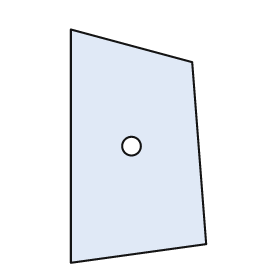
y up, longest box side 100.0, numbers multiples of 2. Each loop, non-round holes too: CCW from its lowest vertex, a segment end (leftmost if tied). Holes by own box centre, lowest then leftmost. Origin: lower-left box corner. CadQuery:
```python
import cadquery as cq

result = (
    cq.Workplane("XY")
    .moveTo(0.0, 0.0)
    .lineTo(58.0, 8.0)
    .lineTo(52.0, 86.0)
    .lineTo(0.0, 100.0)
    .close()
    .moveTo(26.0, 50.0)
    .circle(4.0)
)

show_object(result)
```